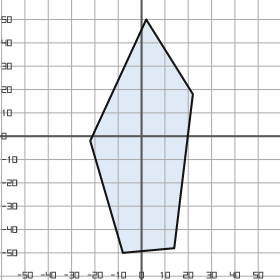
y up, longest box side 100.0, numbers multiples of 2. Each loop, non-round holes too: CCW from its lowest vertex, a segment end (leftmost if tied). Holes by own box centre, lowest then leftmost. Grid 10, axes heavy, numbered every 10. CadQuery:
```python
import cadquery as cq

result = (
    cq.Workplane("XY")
    .moveTo(-8.0, -50.0)
    .lineTo(14.0, -48.0)
    .lineTo(22.0, 18.0)
    .lineTo(2.0, 50.0)
    .lineTo(-22.0, -2.0)
    .close()
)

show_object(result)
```